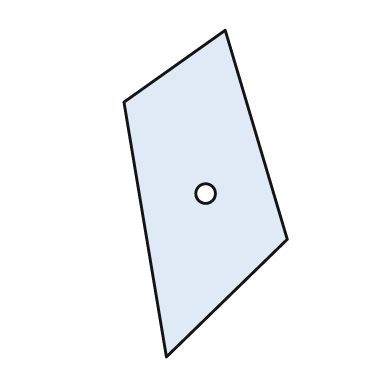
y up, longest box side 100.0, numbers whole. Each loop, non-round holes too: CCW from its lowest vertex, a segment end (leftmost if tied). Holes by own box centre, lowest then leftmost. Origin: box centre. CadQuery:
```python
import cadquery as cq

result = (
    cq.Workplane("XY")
    .moveTo(-12.0, -50.0)
    .lineTo(25.0, -14.0)
    .lineTo(6.0, 50.0)
    .lineTo(-25.0, 28.0)
    .close()
    .moveTo(0.0, 0.0)
    .circle(3.0)
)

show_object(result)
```